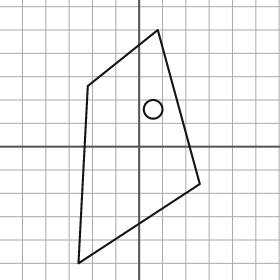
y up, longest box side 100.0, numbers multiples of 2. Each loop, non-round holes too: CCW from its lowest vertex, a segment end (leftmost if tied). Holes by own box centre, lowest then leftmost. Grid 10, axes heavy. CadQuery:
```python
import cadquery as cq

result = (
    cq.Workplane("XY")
    .moveTo(-26.0, -50.0)
    .lineTo(26.0, -16.0)
    .lineTo(8.0, 50.0)
    .lineTo(-22.0, 26.0)
    .close()
    .moveTo(6.0, 16.0)
    .circle(4.0)
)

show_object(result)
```